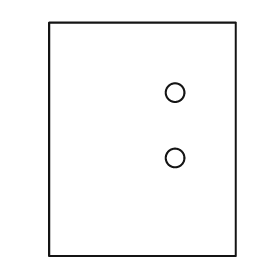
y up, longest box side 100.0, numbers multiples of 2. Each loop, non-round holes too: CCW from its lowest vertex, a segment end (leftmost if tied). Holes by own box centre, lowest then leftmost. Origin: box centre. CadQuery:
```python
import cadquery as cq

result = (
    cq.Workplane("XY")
    .moveTo(-40.0, -50.0)
    .lineTo(40.0, -50.0)
    .lineTo(40.0, 50.0)
    .lineTo(-40.0, 50.0)
    .close()
    .moveTo(14.0, -8.0)
    .circle(4.0)
    .moveTo(14.0, 20.0)
    .circle(4.0)
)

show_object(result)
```